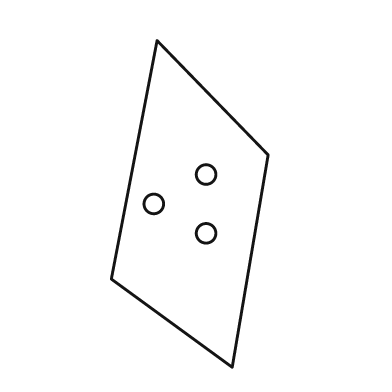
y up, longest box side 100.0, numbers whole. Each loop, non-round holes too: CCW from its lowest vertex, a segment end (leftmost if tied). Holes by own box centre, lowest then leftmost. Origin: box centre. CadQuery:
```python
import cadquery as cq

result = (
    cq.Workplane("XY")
    .moveTo(13.0, -50.0)
    .lineTo(24.0, 15.0)
    .lineTo(-10.0, 50.0)
    .lineTo(-24.0, -23.0)
    .close()
    .moveTo(5.0, -9.0)
    .circle(3.0)
    .moveTo(-11.0, 0.0)
    .circle(3.0)
    .moveTo(5.0, 9.0)
    .circle(3.0)
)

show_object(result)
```